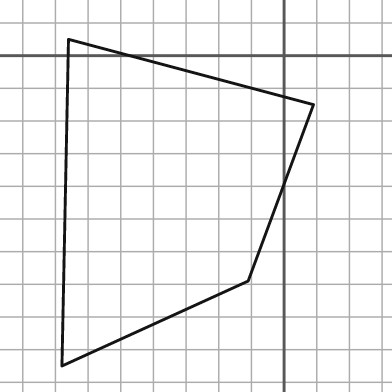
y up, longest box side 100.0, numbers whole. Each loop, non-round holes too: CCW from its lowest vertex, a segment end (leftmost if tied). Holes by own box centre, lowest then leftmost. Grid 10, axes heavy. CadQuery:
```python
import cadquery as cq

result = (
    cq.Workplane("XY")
    .moveTo(-68.0, -95.0)
    .lineTo(-11.0, -69.0)
    .lineTo(9.0, -15.0)
    .lineTo(-66.0, 5.0)
    .close()
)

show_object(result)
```